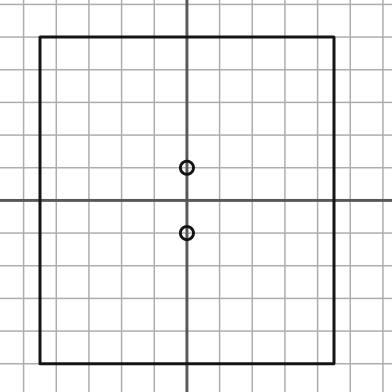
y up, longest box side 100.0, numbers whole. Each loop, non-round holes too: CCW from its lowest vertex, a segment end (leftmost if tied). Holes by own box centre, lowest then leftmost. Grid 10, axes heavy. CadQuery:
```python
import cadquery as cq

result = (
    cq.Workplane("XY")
    .moveTo(-45.0, -50.0)
    .lineTo(45.0, -50.0)
    .lineTo(45.0, 50.0)
    .lineTo(-45.0, 50.0)
    .close()
    .moveTo(0.0, -10.0)
    .circle(2.0)
    .moveTo(0.0, 10.0)
    .circle(2.0)
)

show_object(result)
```